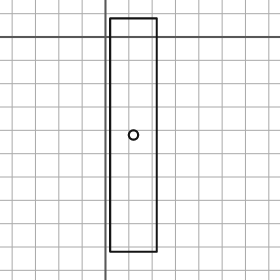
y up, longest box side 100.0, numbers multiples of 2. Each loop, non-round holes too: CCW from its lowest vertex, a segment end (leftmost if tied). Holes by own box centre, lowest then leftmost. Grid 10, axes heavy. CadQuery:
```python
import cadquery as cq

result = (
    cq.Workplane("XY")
    .moveTo(2.0, -92.0)
    .lineTo(22.0, -92.0)
    .lineTo(22.0, 8.0)
    .lineTo(2.0, 8.0)
    .close()
    .moveTo(12.0, -42.0)
    .circle(2.0)
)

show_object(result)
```